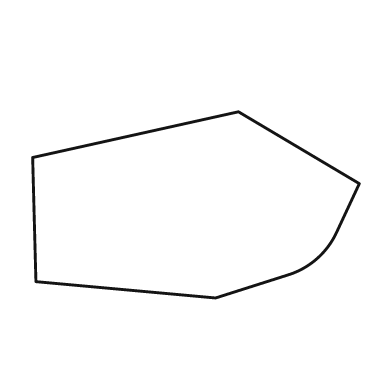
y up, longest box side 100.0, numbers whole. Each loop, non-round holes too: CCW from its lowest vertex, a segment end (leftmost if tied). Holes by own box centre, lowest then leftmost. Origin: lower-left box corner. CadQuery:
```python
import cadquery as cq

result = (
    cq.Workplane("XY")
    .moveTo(56.0, 0.0)
    .lineTo(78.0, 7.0)
    .threePointArc((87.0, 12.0), (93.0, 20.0))
    .lineTo(100.0, 35.0)
    .lineTo(63.0, 57.0)
    .lineTo(0.0, 43.0)
    .lineTo(1.0, 5.0)
    .close()
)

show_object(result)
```